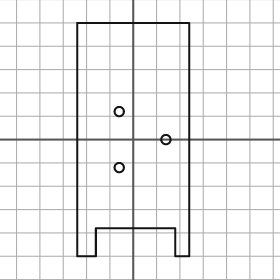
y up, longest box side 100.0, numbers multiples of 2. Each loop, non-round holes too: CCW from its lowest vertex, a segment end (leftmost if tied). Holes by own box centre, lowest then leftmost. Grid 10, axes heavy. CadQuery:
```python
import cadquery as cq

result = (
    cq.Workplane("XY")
    .moveTo(-24.0, -50.0)
    .lineTo(-16.0, -50.0)
    .lineTo(-16.0, -38.0)
    .lineTo(18.0, -38.0)
    .lineTo(18.0, -50.0)
    .lineTo(24.0, -50.0)
    .lineTo(24.0, 50.0)
    .lineTo(-24.0, 50.0)
    .close()
    .moveTo(-6.0, -12.0)
    .circle(2.0)
    .moveTo(14.0, 0.0)
    .circle(2.0)
    .moveTo(-6.0, 12.0)
    .circle(2.0)
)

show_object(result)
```